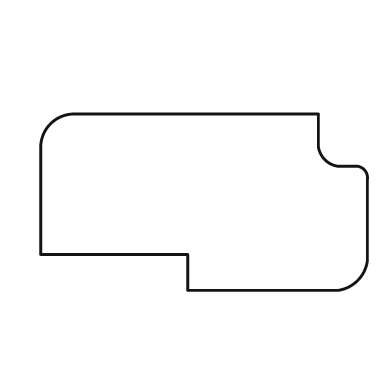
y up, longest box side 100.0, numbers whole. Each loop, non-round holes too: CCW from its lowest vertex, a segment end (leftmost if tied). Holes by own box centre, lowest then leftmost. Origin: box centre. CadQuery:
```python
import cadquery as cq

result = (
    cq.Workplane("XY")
    .moveTo(-5.0, -27.0)
    .lineTo(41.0, -27.0)
    .threePointArc((47.0, -24.0), (50.0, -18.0))
    .lineTo(50.0, 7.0)
    .threePointArc((49.0, 10.0), (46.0, 11.0))
    .lineTo(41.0, 11.0)
    .threePointArc((37.0, 13.0), (35.0, 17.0))
    .lineTo(35.0, 27.0)
    .lineTo(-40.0, 27.0)
    .threePointArc((-47.0, 24.0), (-50.0, 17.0))
    .lineTo(-50.0, -16.0)
    .lineTo(-5.0, -16.0)
    .close()
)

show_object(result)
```